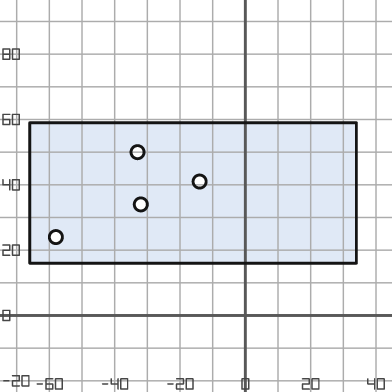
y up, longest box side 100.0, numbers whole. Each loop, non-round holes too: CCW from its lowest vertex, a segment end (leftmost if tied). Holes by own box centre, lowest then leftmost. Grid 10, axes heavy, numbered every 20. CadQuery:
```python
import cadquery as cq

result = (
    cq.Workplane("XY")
    .moveTo(-66.0, 16.0)
    .lineTo(34.0, 16.0)
    .lineTo(34.0, 59.0)
    .lineTo(-66.0, 59.0)
    .close()
    .moveTo(-58.0, 24.0)
    .circle(2.0)
    .moveTo(-32.0, 34.0)
    .circle(2.0)
    .moveTo(-14.0, 41.0)
    .circle(2.0)
    .moveTo(-33.0, 50.0)
    .circle(2.0)
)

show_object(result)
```